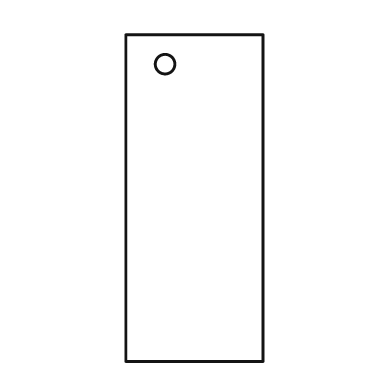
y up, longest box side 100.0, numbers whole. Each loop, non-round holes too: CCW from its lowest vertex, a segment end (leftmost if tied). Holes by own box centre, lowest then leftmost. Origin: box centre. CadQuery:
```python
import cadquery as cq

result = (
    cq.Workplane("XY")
    .moveTo(-21.0, -50.0)
    .lineTo(21.0, -50.0)
    .lineTo(21.0, 50.0)
    .lineTo(-21.0, 50.0)
    .close()
    .moveTo(-9.0, 41.0)
    .circle(3.0)
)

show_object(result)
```